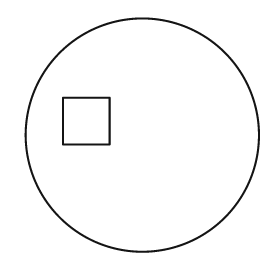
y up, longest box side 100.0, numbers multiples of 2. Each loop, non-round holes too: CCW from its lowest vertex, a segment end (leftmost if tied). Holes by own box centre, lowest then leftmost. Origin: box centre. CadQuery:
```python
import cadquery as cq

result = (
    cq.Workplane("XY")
    .moveTo(0.0, 0.0)
    .circle(50.0)
    .moveTo(-34.0, -4.0)
    .lineTo(-14.0, -4.0)
    .lineTo(-14.0, 16.0)
    .lineTo(-34.0, 16.0)
    .close()
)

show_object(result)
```